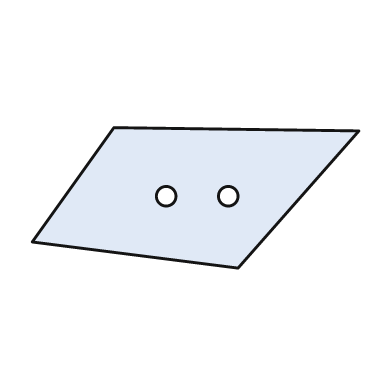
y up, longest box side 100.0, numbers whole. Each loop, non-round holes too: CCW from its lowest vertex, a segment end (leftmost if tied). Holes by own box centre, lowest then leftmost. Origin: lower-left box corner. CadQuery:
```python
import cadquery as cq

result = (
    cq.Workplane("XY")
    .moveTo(63.0, 0.0)
    .lineTo(100.0, 42.0)
    .lineTo(25.0, 43.0)
    .lineTo(0.0, 8.0)
    .close()
    .moveTo(41.0, 22.0)
    .circle(3.0)
    .moveTo(60.0, 22.0)
    .circle(3.0)
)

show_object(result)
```